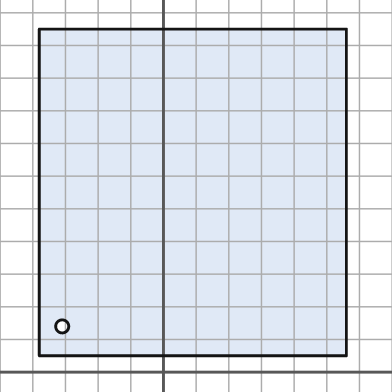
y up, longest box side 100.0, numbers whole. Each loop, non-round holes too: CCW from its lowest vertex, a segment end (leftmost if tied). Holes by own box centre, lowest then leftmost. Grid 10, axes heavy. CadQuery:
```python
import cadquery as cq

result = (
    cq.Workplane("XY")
    .moveTo(-38.0, 5.0)
    .lineTo(56.0, 5.0)
    .lineTo(56.0, 105.0)
    .lineTo(-38.0, 105.0)
    .close()
    .moveTo(-31.0, 14.0)
    .circle(2.0)
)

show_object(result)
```